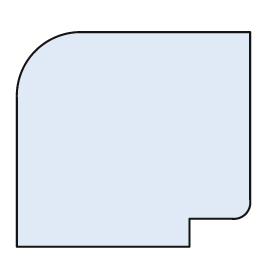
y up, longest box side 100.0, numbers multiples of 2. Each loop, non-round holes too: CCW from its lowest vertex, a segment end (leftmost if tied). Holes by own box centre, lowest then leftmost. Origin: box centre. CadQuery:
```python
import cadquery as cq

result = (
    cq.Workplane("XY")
    .moveTo(-50.0, -46.0)
    .lineTo(24.0, -46.0)
    .lineTo(24.0, -34.0)
    .lineTo(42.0, -34.0)
    .threePointArc((48.0, -32.0), (50.0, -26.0))
    .lineTo(50.0, 46.0)
    .lineTo(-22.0, 46.0)
    .threePointArc((-42.0, 38.0), (-50.0, 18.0))
    .close()
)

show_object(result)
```